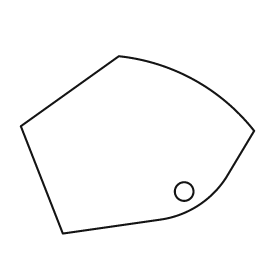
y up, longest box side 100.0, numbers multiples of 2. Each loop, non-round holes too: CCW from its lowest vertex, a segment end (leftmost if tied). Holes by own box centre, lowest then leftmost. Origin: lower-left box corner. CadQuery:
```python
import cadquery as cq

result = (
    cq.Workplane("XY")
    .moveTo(18.0, 0.0)
    .lineTo(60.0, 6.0)
    .threePointArc((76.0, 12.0), (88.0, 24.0))
    .lineTo(100.0, 44.0)
    .threePointArc((74.0, 66.0), (42.0, 76.0))
    .lineTo(0.0, 46.0)
    .close()
    .moveTo(70.0, 18.0)
    .circle(4.0)
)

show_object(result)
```